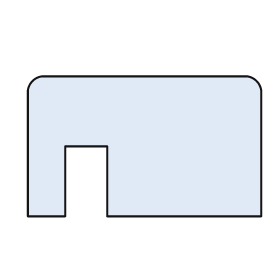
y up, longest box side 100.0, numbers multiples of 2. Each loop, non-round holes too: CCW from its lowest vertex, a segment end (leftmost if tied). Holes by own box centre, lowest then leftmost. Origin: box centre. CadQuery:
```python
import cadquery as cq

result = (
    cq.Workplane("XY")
    .moveTo(-50.0, -30.0)
    .lineTo(-34.0, -30.0)
    .lineTo(-34.0, 0.0)
    .lineTo(-16.0, 0.0)
    .lineTo(-16.0, -30.0)
    .lineTo(50.0, -30.0)
    .lineTo(50.0, 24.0)
    .threePointArc((48.0, 28.0), (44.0, 30.0))
    .lineTo(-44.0, 30.0)
    .threePointArc((-48.0, 28.0), (-50.0, 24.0))
    .close()
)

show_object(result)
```